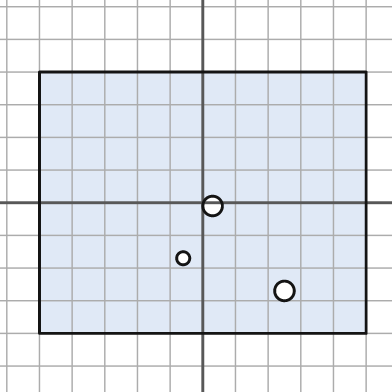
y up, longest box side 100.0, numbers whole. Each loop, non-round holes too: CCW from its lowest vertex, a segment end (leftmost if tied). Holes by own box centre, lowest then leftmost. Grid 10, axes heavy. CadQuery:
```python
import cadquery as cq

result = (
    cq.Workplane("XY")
    .moveTo(-50.0, -40.0)
    .lineTo(50.0, -40.0)
    .lineTo(50.0, 40.0)
    .lineTo(-50.0, 40.0)
    .close()
    .moveTo(25.0, -27.0)
    .circle(3.0)
    .moveTo(-6.0, -17.0)
    .circle(2.0)
    .moveTo(3.0, -1.0)
    .circle(3.0)
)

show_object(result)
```